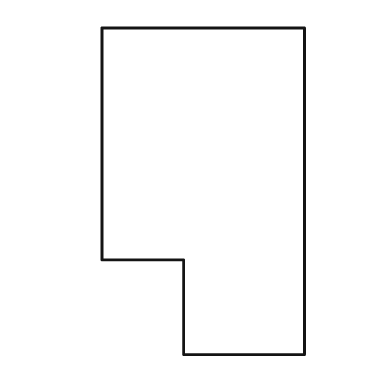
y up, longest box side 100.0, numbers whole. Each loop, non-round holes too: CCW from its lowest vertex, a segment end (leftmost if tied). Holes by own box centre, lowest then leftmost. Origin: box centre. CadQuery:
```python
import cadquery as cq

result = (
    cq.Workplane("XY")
    .moveTo(-6.0, -50.0)
    .lineTo(31.0, -50.0)
    .lineTo(31.0, 50.0)
    .lineTo(-31.0, 50.0)
    .lineTo(-31.0, -21.0)
    .lineTo(-6.0, -21.0)
    .close()
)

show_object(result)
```